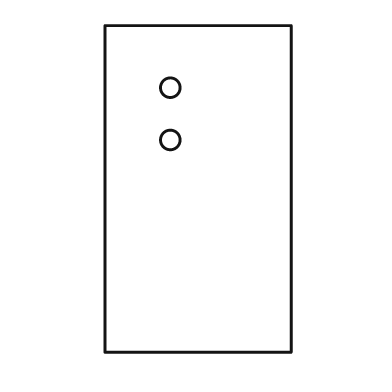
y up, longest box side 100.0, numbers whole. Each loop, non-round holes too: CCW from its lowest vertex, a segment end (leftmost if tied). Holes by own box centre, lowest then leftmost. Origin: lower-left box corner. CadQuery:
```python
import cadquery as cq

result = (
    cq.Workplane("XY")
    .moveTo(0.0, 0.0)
    .lineTo(57.0, 0.0)
    .lineTo(57.0, 100.0)
    .lineTo(0.0, 100.0)
    .close()
    .moveTo(20.0, 65.0)
    .circle(3.0)
    .moveTo(20.0, 81.0)
    .circle(3.0)
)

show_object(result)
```